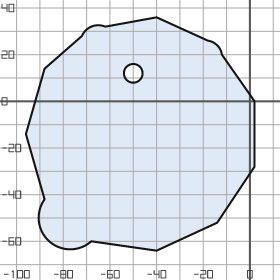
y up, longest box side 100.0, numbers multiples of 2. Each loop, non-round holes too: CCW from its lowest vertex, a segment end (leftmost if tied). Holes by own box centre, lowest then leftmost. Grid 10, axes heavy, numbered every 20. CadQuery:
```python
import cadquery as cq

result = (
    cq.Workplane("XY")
    .moveTo(-40.0, -64.0)
    .lineTo(-14.0, -52.0)
    .lineTo(2.0, -28.0)
    .lineTo(2.0, 0.0)
    .lineTo(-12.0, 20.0)
    .threePointArc((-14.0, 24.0), (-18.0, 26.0))
    .lineTo(-40.0, 36.0)
    .lineTo(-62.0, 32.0)
    .threePointArc((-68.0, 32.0), (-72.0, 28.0))
    .lineTo(-88.0, 14.0)
    .lineTo(-96.0, -14.0)
    .lineTo(-88.0, -42.0)
    .threePointArc((-86.0, -60.0), (-68.0, -60.0))
    .close()
    .moveTo(-50.0, 12.0)
    .circle(4.0)
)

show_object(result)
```